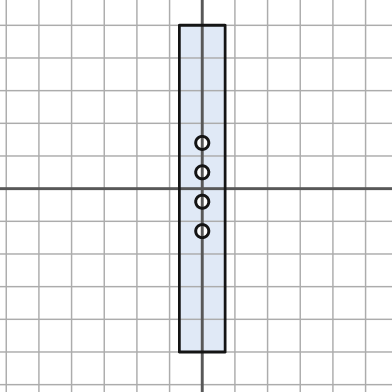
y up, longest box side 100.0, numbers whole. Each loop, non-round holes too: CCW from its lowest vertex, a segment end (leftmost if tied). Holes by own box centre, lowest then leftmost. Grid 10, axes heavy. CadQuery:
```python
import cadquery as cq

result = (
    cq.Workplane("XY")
    .moveTo(-7.0, -50.0)
    .lineTo(7.0, -50.0)
    .lineTo(7.0, 50.0)
    .lineTo(-7.0, 50.0)
    .close()
    .moveTo(0.0, -13.0)
    .circle(2.0)
    .moveTo(0.0, -4.0)
    .circle(2.0)
    .moveTo(0.0, 5.0)
    .circle(2.0)
    .moveTo(0.0, 14.0)
    .circle(2.0)
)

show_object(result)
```